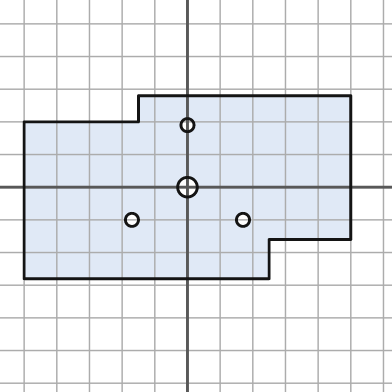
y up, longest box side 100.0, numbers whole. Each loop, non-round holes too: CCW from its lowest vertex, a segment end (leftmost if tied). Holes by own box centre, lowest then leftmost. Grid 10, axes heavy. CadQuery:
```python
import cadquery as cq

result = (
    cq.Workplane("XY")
    .moveTo(-50.0, -28.0)
    .lineTo(25.0, -28.0)
    .lineTo(25.0, -16.0)
    .lineTo(50.0, -16.0)
    .lineTo(50.0, 28.0)
    .lineTo(-15.0, 28.0)
    .lineTo(-15.0, 20.0)
    .lineTo(-50.0, 20.0)
    .close()
    .moveTo(-17.0, -10.0)
    .circle(2.0)
    .moveTo(17.0, -10.0)
    .circle(2.0)
    .moveTo(0.0, 0.0)
    .circle(3.0)
    .moveTo(0.0, 19.0)
    .circle(2.0)
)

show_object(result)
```